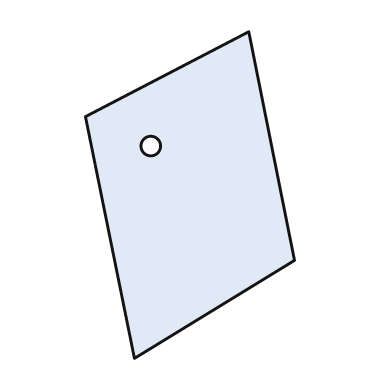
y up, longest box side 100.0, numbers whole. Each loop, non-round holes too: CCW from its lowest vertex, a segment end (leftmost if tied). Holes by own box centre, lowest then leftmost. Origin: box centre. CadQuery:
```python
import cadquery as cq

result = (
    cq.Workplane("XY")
    .moveTo(-17.0, -50.0)
    .lineTo(32.0, -20.0)
    .lineTo(18.0, 50.0)
    .lineTo(-32.0, 24.0)
    .close()
    .moveTo(-12.0, 15.0)
    .circle(3.0)
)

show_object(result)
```